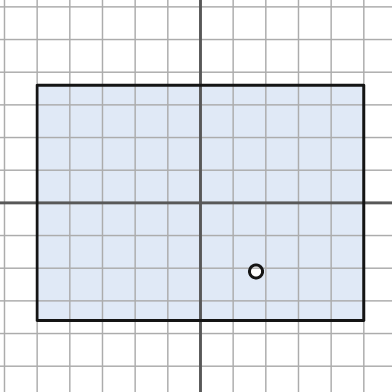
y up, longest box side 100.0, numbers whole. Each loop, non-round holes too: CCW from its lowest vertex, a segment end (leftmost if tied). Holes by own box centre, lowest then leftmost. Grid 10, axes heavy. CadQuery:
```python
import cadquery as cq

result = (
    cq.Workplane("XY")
    .moveTo(-50.0, -36.0)
    .lineTo(50.0, -36.0)
    .lineTo(50.0, 36.0)
    .lineTo(-50.0, 36.0)
    .close()
    .moveTo(17.0, -21.0)
    .circle(2.0)
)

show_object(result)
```